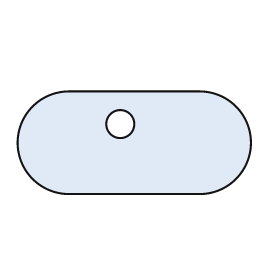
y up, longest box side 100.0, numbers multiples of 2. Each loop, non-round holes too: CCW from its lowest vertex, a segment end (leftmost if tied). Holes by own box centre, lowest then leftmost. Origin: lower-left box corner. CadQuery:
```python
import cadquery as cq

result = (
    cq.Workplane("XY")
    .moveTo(22.0, 0.0)
    .lineTo(78.0, 0.0)
    .threePointArc((100.0, 22.0), (78.0, 44.0))
    .lineTo(22.0, 44.0)
    .threePointArc((0.0, 22.0), (22.0, 0.0))
    .close()
    .moveTo(44.0, 30.0)
    .circle(6.0)
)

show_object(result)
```